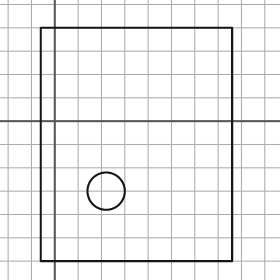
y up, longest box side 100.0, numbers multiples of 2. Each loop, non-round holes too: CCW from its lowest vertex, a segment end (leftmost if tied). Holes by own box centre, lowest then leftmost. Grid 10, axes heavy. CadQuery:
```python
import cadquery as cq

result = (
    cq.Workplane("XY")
    .moveTo(-6.0, -60.0)
    .lineTo(76.0, -60.0)
    .lineTo(76.0, 40.0)
    .lineTo(-6.0, 40.0)
    .close()
    .moveTo(22.0, -30.0)
    .circle(8.0)
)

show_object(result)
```